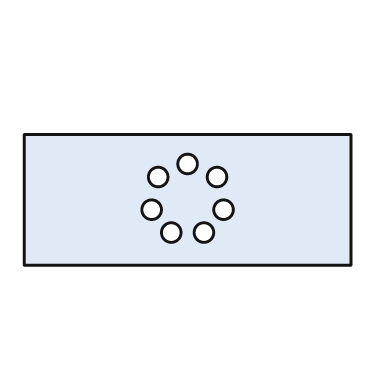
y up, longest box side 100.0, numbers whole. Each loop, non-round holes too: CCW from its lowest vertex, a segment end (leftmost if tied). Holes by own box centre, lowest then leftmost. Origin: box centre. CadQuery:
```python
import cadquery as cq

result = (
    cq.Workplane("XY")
    .moveTo(-50.0, -20.0)
    .lineTo(50.0, -20.0)
    .lineTo(50.0, 20.0)
    .lineTo(-50.0, 20.0)
    .close()
    .moveTo(-5.0, -10.0)
    .circle(3.0)
    .moveTo(5.0, -10.0)
    .circle(3.0)
    .moveTo(-11.0, -3.0)
    .circle(3.0)
    .moveTo(11.0, -3.0)
    .circle(3.0)
    .moveTo(-9.0, 7.0)
    .circle(3.0)
    .moveTo(9.0, 7.0)
    .circle(3.0)
    .moveTo(0.0, 11.0)
    .circle(3.0)
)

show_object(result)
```